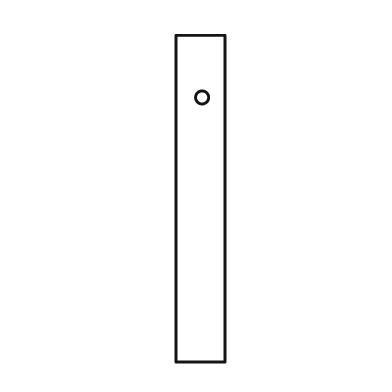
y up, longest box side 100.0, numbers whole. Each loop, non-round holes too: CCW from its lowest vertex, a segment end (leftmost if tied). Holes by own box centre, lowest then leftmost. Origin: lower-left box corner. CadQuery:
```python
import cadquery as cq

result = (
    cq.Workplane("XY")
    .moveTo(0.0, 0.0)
    .lineTo(15.0, 0.0)
    .lineTo(15.0, 100.0)
    .lineTo(0.0, 100.0)
    .close()
    .moveTo(8.0, 81.0)
    .circle(2.0)
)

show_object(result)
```